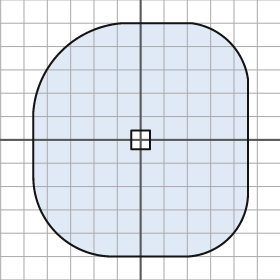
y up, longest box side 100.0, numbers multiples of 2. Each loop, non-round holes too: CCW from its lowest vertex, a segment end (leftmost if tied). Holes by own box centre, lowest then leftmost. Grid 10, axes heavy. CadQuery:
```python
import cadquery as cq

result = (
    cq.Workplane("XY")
    .moveTo(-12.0, -50.0)
    .lineTo(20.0, -50.0)
    .threePointArc((38.0, -42.0), (46.0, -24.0))
    .lineTo(46.0, 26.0)
    .threePointArc((38.0, 42.0), (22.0, 50.0))
    .lineTo(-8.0, 50.0)
    .threePointArc((-34.0, 38.0), (-46.0, 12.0))
    .lineTo(-46.0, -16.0)
    .threePointArc((-36.0, -40.0), (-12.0, -50.0))
    .close()
    .moveTo(-4.0, -4.0)
    .lineTo(4.0, -4.0)
    .lineTo(4.0, 4.0)
    .lineTo(-4.0, 4.0)
    .close()
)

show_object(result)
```